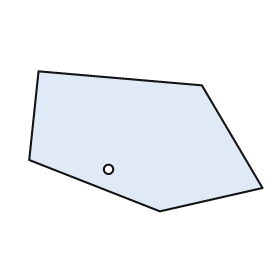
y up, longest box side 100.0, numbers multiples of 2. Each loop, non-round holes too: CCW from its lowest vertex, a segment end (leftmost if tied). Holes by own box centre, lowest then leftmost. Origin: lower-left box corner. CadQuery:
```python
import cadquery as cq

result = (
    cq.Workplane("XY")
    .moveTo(56.0, 0.0)
    .lineTo(100.0, 10.0)
    .lineTo(74.0, 54.0)
    .lineTo(4.0, 60.0)
    .lineTo(0.0, 22.0)
    .close()
    .moveTo(34.0, 18.0)
    .circle(2.0)
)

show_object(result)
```